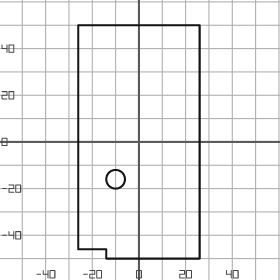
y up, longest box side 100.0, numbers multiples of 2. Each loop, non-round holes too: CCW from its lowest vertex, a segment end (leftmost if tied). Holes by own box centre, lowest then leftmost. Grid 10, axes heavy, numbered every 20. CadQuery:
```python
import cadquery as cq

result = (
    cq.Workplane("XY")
    .moveTo(-14.0, -50.0)
    .lineTo(26.0, -50.0)
    .lineTo(26.0, 50.0)
    .lineTo(-26.0, 50.0)
    .lineTo(-26.0, -46.0)
    .lineTo(-14.0, -46.0)
    .close()
    .moveTo(-10.0, -16.0)
    .circle(4.0)
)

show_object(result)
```